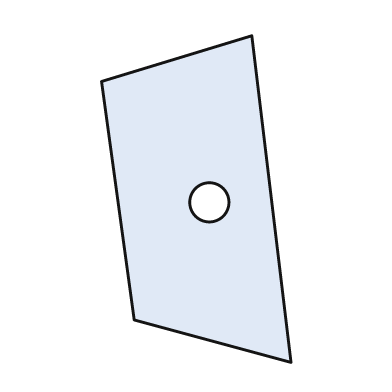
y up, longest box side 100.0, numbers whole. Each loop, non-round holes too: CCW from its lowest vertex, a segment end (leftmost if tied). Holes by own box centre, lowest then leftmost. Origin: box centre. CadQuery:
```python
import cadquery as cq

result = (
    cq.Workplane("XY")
    .moveTo(29.0, -50.0)
    .lineTo(17.0, 50.0)
    .lineTo(-29.0, 36.0)
    .lineTo(-19.0, -37.0)
    .close()
    .moveTo(4.0, -1.0)
    .circle(6.0)
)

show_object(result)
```